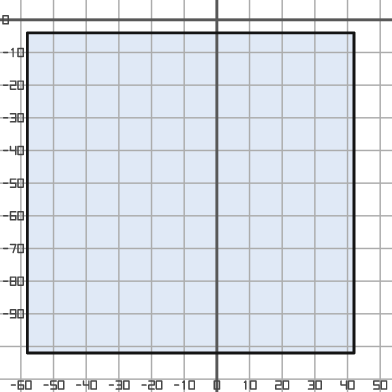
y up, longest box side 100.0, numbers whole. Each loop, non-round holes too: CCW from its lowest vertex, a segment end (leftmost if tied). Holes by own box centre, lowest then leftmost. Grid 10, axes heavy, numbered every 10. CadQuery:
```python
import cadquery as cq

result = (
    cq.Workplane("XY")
    .moveTo(-58.0, -102.0)
    .lineTo(42.0, -102.0)
    .lineTo(42.0, -4.0)
    .lineTo(-58.0, -4.0)
    .close()
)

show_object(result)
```